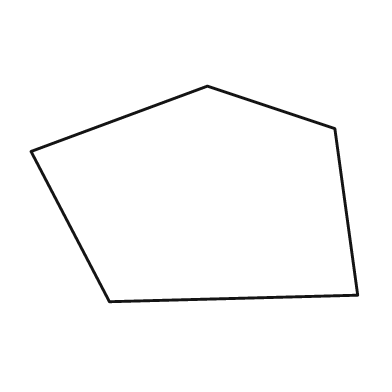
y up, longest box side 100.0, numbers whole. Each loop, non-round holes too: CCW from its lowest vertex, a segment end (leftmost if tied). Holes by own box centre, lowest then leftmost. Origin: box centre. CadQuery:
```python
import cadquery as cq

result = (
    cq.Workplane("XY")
    .moveTo(-26.0, -33.0)
    .lineTo(50.0, -31.0)
    .lineTo(43.0, 20.0)
    .lineTo(4.0, 33.0)
    .lineTo(-50.0, 13.0)
    .close()
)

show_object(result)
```